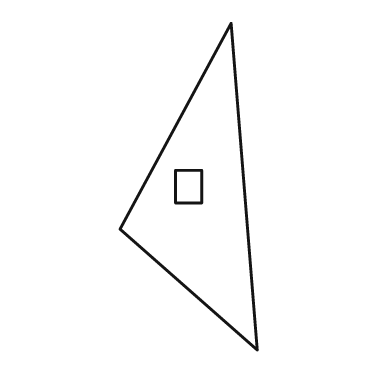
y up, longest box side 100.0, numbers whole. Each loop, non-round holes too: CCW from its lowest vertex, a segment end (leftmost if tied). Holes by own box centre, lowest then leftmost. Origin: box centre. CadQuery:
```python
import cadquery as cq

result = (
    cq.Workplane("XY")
    .moveTo(21.0, -50.0)
    .lineTo(13.0, 50.0)
    .lineTo(-21.0, -13.0)
    .close()
    .moveTo(-4.0, -5.0)
    .lineTo(4.0, -5.0)
    .lineTo(4.0, 5.0)
    .lineTo(-4.0, 5.0)
    .close()
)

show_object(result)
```